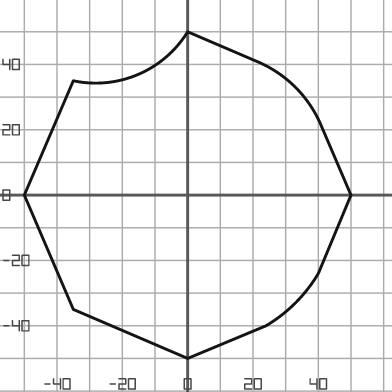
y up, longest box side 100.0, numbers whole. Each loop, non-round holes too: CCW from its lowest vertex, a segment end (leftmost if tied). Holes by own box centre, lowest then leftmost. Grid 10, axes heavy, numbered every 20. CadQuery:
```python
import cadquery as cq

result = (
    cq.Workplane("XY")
    .moveTo(0.0, -50.0)
    .lineTo(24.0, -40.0)
    .threePointArc((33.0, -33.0), (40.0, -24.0))
    .lineTo(50.0, 0.0)
    .lineTo(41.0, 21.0)
    .threePointArc((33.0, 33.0), (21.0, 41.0))
    .lineTo(0.0, 50.0)
    .threePointArc((-15.0, 37.0), (-35.0, 35.0))
    .lineTo(-50.0, 0.0)
    .lineTo(-35.0, -35.0)
    .close()
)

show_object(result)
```